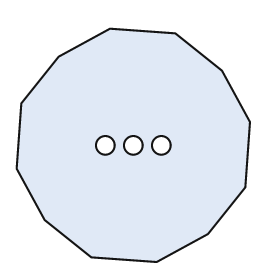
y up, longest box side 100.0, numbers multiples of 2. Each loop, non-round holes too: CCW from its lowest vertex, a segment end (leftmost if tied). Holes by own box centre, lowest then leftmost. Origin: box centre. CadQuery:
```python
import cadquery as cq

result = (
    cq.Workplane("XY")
    .moveTo(10.0, -50.0)
    .lineTo(32.0, -38.0)
    .lineTo(48.0, -18.0)
    .lineTo(50.0, 10.0)
    .lineTo(38.0, 32.0)
    .lineTo(18.0, 48.0)
    .lineTo(-10.0, 50.0)
    .lineTo(-32.0, 38.0)
    .lineTo(-48.0, 18.0)
    .lineTo(-50.0, -10.0)
    .lineTo(-38.0, -32.0)
    .lineTo(-18.0, -48.0)
    .close()
    .moveTo(-12.0, 0.0)
    .circle(4.0)
    .moveTo(0.0, 0.0)
    .circle(4.0)
    .moveTo(12.0, 0.0)
    .circle(4.0)
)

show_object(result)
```